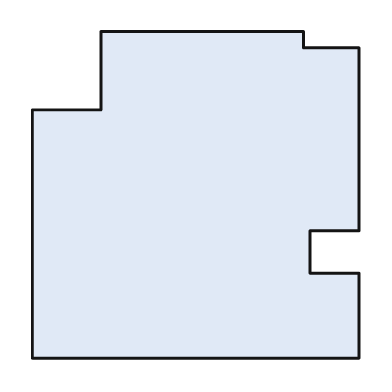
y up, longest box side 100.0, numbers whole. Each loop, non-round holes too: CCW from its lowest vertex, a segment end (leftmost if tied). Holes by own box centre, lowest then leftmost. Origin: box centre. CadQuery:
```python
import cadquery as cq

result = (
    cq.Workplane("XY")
    .moveTo(-50.0, -50.0)
    .lineTo(50.0, -50.0)
    .lineTo(50.0, -24.0)
    .lineTo(35.0, -24.0)
    .lineTo(35.0, -11.0)
    .lineTo(50.0, -11.0)
    .lineTo(50.0, 45.0)
    .lineTo(33.0, 45.0)
    .lineTo(33.0, 50.0)
    .lineTo(-29.0, 50.0)
    .lineTo(-29.0, 26.0)
    .lineTo(-50.0, 26.0)
    .close()
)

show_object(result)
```